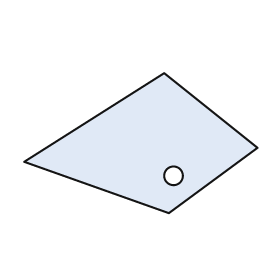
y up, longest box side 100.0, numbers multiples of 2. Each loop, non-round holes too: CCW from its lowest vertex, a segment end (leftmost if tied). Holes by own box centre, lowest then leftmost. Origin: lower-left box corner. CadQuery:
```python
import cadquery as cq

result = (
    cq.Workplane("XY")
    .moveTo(62.0, 0.0)
    .lineTo(100.0, 28.0)
    .lineTo(60.0, 60.0)
    .lineTo(0.0, 22.0)
    .close()
    .moveTo(64.0, 16.0)
    .circle(4.0)
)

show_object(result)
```